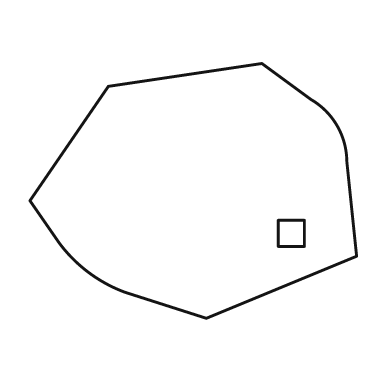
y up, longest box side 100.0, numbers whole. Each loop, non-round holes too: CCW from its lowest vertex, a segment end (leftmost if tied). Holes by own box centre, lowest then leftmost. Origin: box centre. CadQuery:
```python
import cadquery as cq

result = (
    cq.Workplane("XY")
    .moveTo(4.0, -39.0)
    .lineTo(50.0, -20.0)
    .lineTo(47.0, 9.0)
    .threePointArc((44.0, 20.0), (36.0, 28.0))
    .lineTo(21.0, 39.0)
    .lineTo(-26.0, 32.0)
    .lineTo(-50.0, -3.0)
    .lineTo(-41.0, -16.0)
    .threePointArc((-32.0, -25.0), (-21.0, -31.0))
    .close()
    .moveTo(26.0, -17.0)
    .lineTo(34.0, -17.0)
    .lineTo(34.0, -9.0)
    .lineTo(26.0, -9.0)
    .close()
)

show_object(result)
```